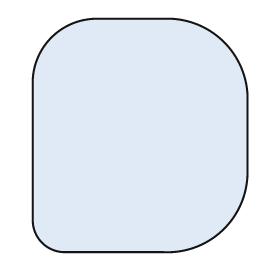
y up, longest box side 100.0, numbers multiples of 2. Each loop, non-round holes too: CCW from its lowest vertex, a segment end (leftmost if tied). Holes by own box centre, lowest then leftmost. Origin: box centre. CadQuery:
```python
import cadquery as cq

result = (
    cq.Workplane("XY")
    .moveTo(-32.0, -50.0)
    .lineTo(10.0, -50.0)
    .threePointArc((36.0, -40.0), (46.0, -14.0))
    .lineTo(46.0, 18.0)
    .threePointArc((36.0, 40.0), (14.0, 50.0))
    .lineTo(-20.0, 50.0)
    .threePointArc((-38.0, 42.0), (-46.0, 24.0))
    .lineTo(-46.0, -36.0)
    .threePointArc((-42.0, -46.0), (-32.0, -50.0))
    .close()
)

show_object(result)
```